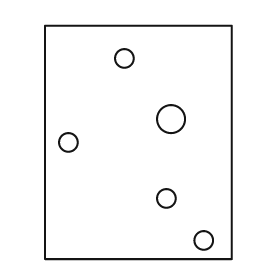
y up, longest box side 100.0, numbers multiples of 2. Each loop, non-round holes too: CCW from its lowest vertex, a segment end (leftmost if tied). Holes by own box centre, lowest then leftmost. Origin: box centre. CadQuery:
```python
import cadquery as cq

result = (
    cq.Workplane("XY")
    .moveTo(-40.0, -50.0)
    .lineTo(40.0, -50.0)
    .lineTo(40.0, 50.0)
    .lineTo(-40.0, 50.0)
    .close()
    .moveTo(28.0, -42.0)
    .circle(4.0)
    .moveTo(12.0, -24.0)
    .circle(4.0)
    .moveTo(-30.0, 0.0)
    .circle(4.0)
    .moveTo(14.0, 10.0)
    .circle(6.0)
    .moveTo(-6.0, 36.0)
    .circle(4.0)
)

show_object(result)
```